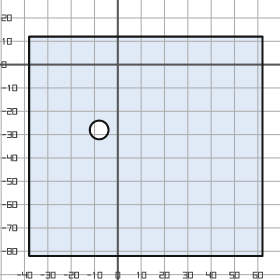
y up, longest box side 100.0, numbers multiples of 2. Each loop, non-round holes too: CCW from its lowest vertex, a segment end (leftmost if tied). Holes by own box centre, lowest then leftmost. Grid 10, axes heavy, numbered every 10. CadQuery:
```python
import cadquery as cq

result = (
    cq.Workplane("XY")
    .moveTo(-38.0, -82.0)
    .lineTo(62.0, -82.0)
    .lineTo(62.0, 12.0)
    .lineTo(-38.0, 12.0)
    .close()
    .moveTo(-8.0, -28.0)
    .circle(4.0)
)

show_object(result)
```